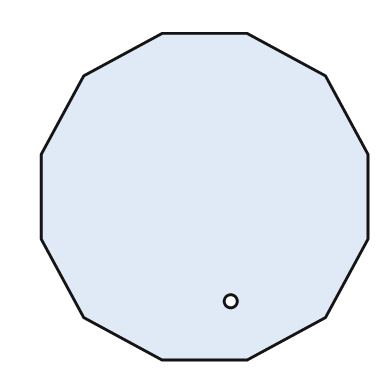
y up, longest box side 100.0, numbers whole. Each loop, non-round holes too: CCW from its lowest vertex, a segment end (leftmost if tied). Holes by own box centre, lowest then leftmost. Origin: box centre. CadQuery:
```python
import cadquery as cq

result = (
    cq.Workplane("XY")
    .moveTo(-13.0, -50.0)
    .lineTo(13.0, -50.0)
    .lineTo(37.0, -37.0)
    .lineTo(50.0, -13.0)
    .lineTo(50.0, 13.0)
    .lineTo(37.0, 37.0)
    .lineTo(13.0, 50.0)
    .lineTo(-13.0, 50.0)
    .lineTo(-37.0, 37.0)
    .lineTo(-50.0, 13.0)
    .lineTo(-50.0, -13.0)
    .lineTo(-37.0, -37.0)
    .close()
    .moveTo(8.0, -32.0)
    .circle(2.0)
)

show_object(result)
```